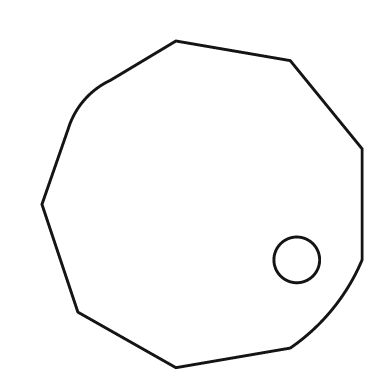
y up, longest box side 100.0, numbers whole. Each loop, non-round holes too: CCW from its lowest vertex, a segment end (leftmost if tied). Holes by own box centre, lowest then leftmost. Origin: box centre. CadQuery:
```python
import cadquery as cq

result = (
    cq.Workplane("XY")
    .moveTo(-8.0, -50.0)
    .lineTo(27.0, -44.0)
    .threePointArc((40.0, -32.0), (49.0, -17.0))
    .lineTo(49.0, 17.0)
    .lineTo(27.0, 44.0)
    .lineTo(-8.0, 50.0)
    .lineTo(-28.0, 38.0)
    .threePointArc((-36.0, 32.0), (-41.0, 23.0))
    .lineTo(-49.0, 0.0)
    .lineTo(-38.0, -33.0)
    .close()
    .moveTo(29.0, -17.0)
    .circle(7.0)
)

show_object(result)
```